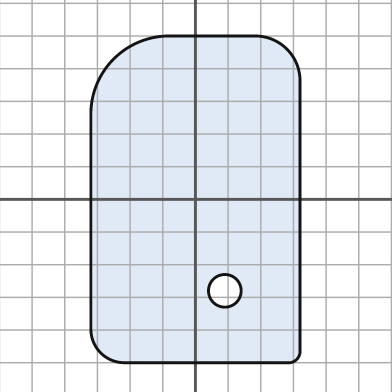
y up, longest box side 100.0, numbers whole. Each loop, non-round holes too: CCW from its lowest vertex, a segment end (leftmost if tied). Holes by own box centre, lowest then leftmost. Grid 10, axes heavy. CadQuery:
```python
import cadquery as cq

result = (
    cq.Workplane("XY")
    .moveTo(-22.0, -50.0)
    .lineTo(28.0, -50.0)
    .threePointArc((31.0, -49.0), (32.0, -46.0))
    .lineTo(32.0, 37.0)
    .threePointArc((28.0, 46.0), (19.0, 50.0))
    .lineTo(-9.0, 50.0)
    .threePointArc((-25.0, 43.0), (-32.0, 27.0))
    .lineTo(-32.0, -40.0)
    .threePointArc((-29.0, -47.0), (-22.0, -50.0))
    .close()
    .moveTo(9.0, -28.0)
    .circle(5.0)
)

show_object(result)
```